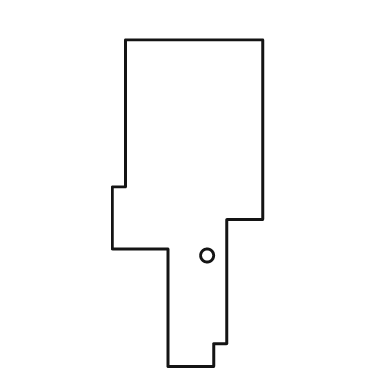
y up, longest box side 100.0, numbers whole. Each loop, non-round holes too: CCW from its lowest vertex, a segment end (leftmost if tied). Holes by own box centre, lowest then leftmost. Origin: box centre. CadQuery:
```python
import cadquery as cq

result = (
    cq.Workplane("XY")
    .moveTo(-6.0, -50.0)
    .lineTo(8.0, -50.0)
    .lineTo(8.0, -43.0)
    .lineTo(12.0, -43.0)
    .lineTo(12.0, -5.0)
    .lineTo(23.0, -5.0)
    .lineTo(23.0, 50.0)
    .lineTo(-19.0, 50.0)
    .lineTo(-19.0, 5.0)
    .lineTo(-23.0, 5.0)
    .lineTo(-23.0, -14.0)
    .lineTo(-6.0, -14.0)
    .close()
    .moveTo(6.0, -16.0)
    .circle(2.0)
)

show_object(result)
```